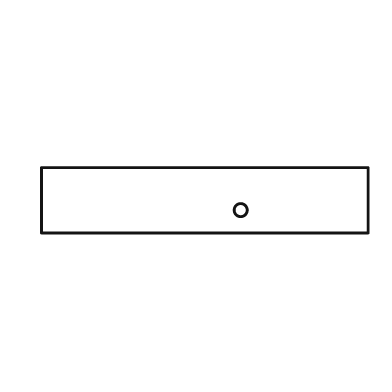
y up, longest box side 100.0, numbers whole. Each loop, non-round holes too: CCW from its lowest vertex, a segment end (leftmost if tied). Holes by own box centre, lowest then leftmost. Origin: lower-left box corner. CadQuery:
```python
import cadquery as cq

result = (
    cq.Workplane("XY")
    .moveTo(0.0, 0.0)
    .lineTo(100.0, 0.0)
    .lineTo(100.0, 20.0)
    .lineTo(0.0, 20.0)
    .close()
    .moveTo(61.0, 7.0)
    .circle(2.0)
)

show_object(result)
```